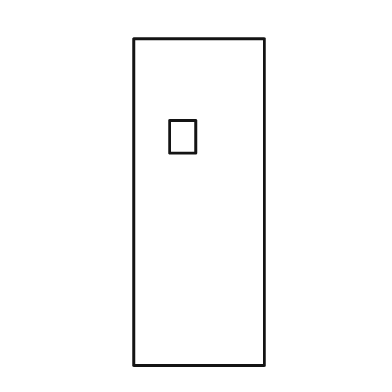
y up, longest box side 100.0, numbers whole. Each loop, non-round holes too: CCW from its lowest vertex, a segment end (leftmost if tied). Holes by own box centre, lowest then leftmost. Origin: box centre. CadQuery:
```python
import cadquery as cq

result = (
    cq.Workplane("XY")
    .moveTo(-20.0, -50.0)
    .lineTo(20.0, -50.0)
    .lineTo(20.0, 50.0)
    .lineTo(-20.0, 50.0)
    .close()
    .moveTo(-9.0, 15.0)
    .lineTo(-1.0, 15.0)
    .lineTo(-1.0, 25.0)
    .lineTo(-9.0, 25.0)
    .close()
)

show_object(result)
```